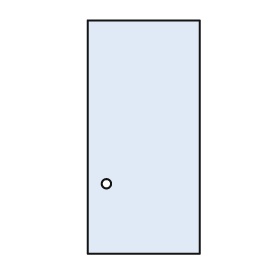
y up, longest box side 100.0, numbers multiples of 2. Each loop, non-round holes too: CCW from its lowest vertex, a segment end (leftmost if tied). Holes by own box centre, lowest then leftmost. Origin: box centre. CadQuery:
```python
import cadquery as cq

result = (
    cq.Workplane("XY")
    .moveTo(-24.0, -50.0)
    .lineTo(24.0, -50.0)
    .lineTo(24.0, 50.0)
    .lineTo(-24.0, 50.0)
    .close()
    .moveTo(-16.0, -20.0)
    .circle(2.0)
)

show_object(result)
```